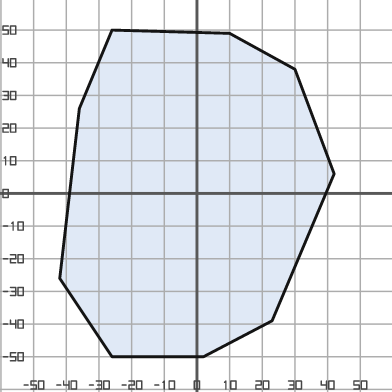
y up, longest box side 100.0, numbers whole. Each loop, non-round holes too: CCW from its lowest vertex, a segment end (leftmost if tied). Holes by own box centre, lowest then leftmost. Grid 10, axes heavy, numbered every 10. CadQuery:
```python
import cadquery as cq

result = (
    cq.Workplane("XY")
    .moveTo(-26.0, -50.0)
    .lineTo(2.0, -50.0)
    .lineTo(23.0, -39.0)
    .lineTo(42.0, 6.0)
    .lineTo(30.0, 38.0)
    .lineTo(10.0, 49.0)
    .lineTo(-26.0, 50.0)
    .lineTo(-36.0, 26.0)
    .lineTo(-42.0, -26.0)
    .close()
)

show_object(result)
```